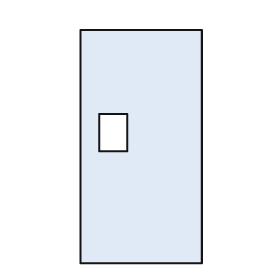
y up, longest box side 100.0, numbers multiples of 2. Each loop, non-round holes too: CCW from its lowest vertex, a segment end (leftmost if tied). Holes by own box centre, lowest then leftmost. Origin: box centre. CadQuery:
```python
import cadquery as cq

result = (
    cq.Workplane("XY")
    .moveTo(-26.0, -50.0)
    .lineTo(26.0, -50.0)
    .lineTo(26.0, 50.0)
    .lineTo(-26.0, 50.0)
    .close()
    .moveTo(-18.0, -2.0)
    .lineTo(-6.0, -2.0)
    .lineTo(-6.0, 14.0)
    .lineTo(-18.0, 14.0)
    .close()
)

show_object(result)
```